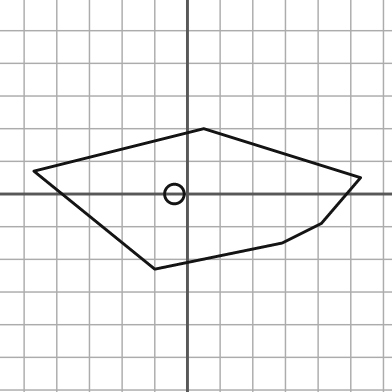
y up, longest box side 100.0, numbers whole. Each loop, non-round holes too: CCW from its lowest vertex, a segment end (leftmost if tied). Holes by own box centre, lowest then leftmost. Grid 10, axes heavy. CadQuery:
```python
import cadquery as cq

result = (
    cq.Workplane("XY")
    .moveTo(-10.0, -23.0)
    .lineTo(29.0, -15.0)
    .lineTo(41.0, -9.0)
    .lineTo(53.0, 5.0)
    .lineTo(5.0, 20.0)
    .lineTo(-47.0, 7.0)
    .close()
    .moveTo(-4.0, 0.0)
    .circle(3.0)
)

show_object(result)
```